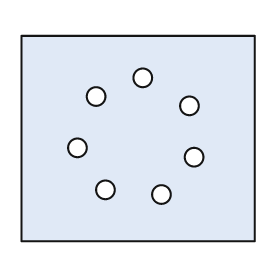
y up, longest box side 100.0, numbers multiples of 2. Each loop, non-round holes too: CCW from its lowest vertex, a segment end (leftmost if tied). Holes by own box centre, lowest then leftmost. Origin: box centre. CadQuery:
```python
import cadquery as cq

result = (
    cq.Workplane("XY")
    .moveTo(-50.0, -44.0)
    .lineTo(50.0, -44.0)
    .lineTo(50.0, 44.0)
    .lineTo(-50.0, 44.0)
    .close()
    .moveTo(10.0, -24.0)
    .circle(4.0)
    .moveTo(-14.0, -22.0)
    .circle(4.0)
    .moveTo(24.0, -8.0)
    .circle(4.0)
    .moveTo(-26.0, -4.0)
    .circle(4.0)
    .moveTo(22.0, 14.0)
    .circle(4.0)
    .moveTo(-18.0, 18.0)
    .circle(4.0)
    .moveTo(2.0, 26.0)
    .circle(4.0)
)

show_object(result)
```